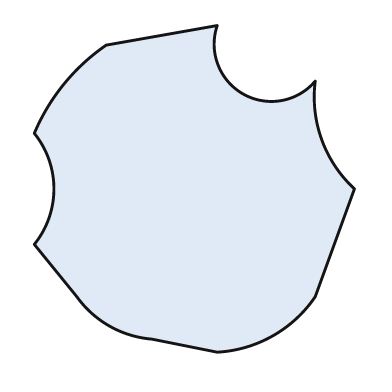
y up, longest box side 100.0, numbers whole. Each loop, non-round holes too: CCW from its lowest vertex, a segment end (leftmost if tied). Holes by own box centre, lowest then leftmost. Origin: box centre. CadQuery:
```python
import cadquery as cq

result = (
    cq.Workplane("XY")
    .moveTo(7.0, -50.0)
    .threePointArc((24.0, -45.0), (37.0, -33.0))
    .lineTo(49.0, 0.0)
    .threePointArc((39.0, 15.0), (37.0, 33.0))
    .threePointArc((15.0, 29.0), (7.0, 50.0))
    .lineTo(-27.0, 44.0)
    .threePointArc((-40.0, 32.0), (-49.0, 17.0))
    .threePointArc((-43.0, 0.0), (-49.0, -17.0))
    .lineTo(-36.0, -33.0)
    .threePointArc((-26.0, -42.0), (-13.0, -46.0))
    .close()
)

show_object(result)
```